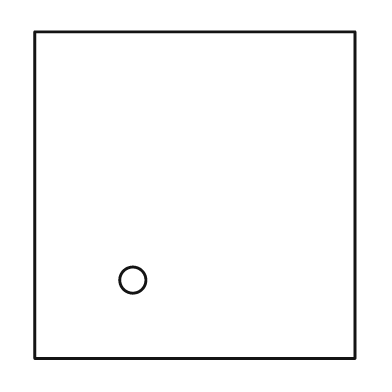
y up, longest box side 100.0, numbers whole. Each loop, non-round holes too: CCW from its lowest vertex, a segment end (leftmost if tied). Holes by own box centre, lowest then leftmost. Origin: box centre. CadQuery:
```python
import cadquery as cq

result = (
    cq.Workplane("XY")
    .moveTo(-49.0, -50.0)
    .lineTo(49.0, -50.0)
    .lineTo(49.0, 50.0)
    .lineTo(-49.0, 50.0)
    .close()
    .moveTo(-19.0, -26.0)
    .circle(4.0)
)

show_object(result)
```